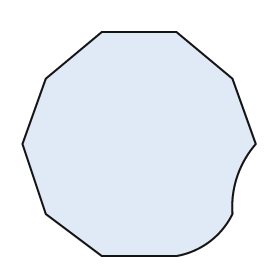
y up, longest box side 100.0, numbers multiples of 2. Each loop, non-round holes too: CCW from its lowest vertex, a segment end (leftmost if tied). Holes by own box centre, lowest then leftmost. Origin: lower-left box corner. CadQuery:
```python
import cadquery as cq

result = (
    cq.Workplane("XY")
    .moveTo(34.0, 0.0)
    .lineTo(66.0, 0.0)
    .threePointArc((80.0, 6.0), (90.0, 18.0))
    .threePointArc((92.0, 34.0), (100.0, 48.0))
    .lineTo(90.0, 76.0)
    .lineTo(66.0, 96.0)
    .lineTo(34.0, 96.0)
    .lineTo(10.0, 76.0)
    .lineTo(0.0, 48.0)
    .lineTo(10.0, 18.0)
    .close()
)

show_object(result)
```